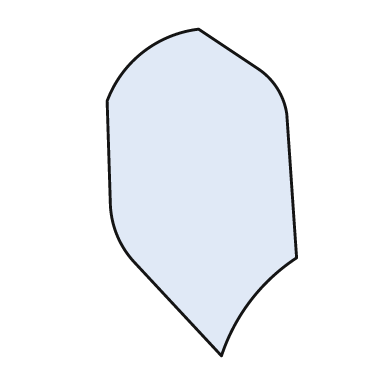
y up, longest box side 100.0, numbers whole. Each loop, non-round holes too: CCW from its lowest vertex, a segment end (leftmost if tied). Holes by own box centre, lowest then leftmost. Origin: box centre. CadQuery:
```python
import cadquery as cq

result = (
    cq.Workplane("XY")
    .moveTo(6.0, -50.0)
    .threePointArc((15.0, -33.0), (29.0, -20.0))
    .lineTo(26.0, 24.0)
    .threePointArc((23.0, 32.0), (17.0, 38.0))
    .lineTo(-1.0, 50.0)
    .threePointArc((-18.0, 43.0), (-29.0, 28.0))
    .lineTo(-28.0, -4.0)
    .threePointArc((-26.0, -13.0), (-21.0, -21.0))
    .close()
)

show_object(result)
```